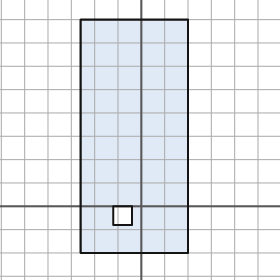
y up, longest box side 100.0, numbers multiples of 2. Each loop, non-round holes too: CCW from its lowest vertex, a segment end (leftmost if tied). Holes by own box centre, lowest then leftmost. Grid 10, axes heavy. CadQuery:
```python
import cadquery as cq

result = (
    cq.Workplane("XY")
    .moveTo(-26.0, -20.0)
    .lineTo(20.0, -20.0)
    .lineTo(20.0, 80.0)
    .lineTo(-26.0, 80.0)
    .close()
    .moveTo(-12.0, -8.0)
    .lineTo(-4.0, -8.0)
    .lineTo(-4.0, 0.0)
    .lineTo(-12.0, 0.0)
    .close()
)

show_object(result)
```